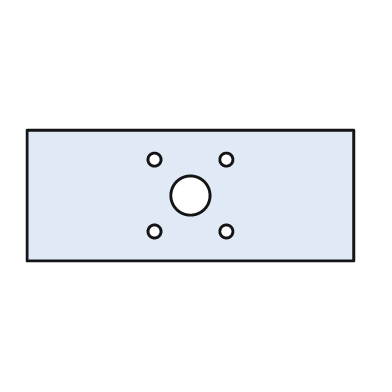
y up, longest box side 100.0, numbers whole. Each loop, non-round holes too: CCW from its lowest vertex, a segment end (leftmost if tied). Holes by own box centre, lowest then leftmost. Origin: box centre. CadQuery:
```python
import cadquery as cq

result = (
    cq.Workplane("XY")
    .moveTo(-50.0, -20.0)
    .lineTo(50.0, -20.0)
    .lineTo(50.0, 20.0)
    .lineTo(-50.0, 20.0)
    .close()
    .moveTo(-11.0, -11.0)
    .circle(2.0)
    .moveTo(11.0, -11.0)
    .circle(2.0)
    .moveTo(0.0, 0.0)
    .circle(6.0)
    .moveTo(-11.0, 11.0)
    .circle(2.0)
    .moveTo(11.0, 11.0)
    .circle(2.0)
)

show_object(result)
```